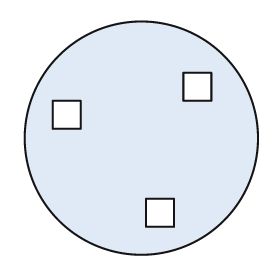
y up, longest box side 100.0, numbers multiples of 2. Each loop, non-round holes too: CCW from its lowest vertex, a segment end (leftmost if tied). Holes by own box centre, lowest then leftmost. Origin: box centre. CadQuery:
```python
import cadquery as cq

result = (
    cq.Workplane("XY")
    .moveTo(0.0, 0.0)
    .circle(50.0)
    .moveTo(2.0, -38.0)
    .lineTo(14.0, -38.0)
    .lineTo(14.0, -26.0)
    .lineTo(2.0, -26.0)
    .close()
    .moveTo(-38.0, 4.0)
    .lineTo(-26.0, 4.0)
    .lineTo(-26.0, 16.0)
    .lineTo(-38.0, 16.0)
    .close()
    .moveTo(18.0, 16.0)
    .lineTo(30.0, 16.0)
    .lineTo(30.0, 28.0)
    .lineTo(18.0, 28.0)
    .close()
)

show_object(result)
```